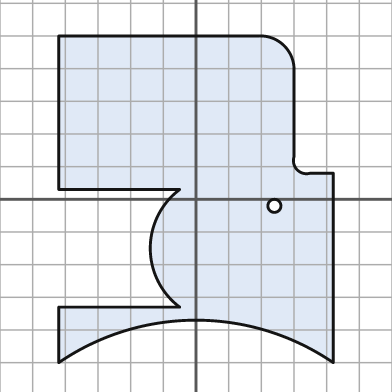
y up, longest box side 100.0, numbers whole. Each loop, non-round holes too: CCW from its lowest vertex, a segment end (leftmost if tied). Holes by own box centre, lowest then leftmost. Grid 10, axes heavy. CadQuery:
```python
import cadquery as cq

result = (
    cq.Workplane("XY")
    .moveTo(-42.0, -50.0)
    .threePointArc((0.0, -37.0), (42.0, -50.0))
    .lineTo(42.0, 8.0)
    .lineTo(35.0, 8.0)
    .threePointArc((31.0, 9.0), (30.0, 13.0))
    .lineTo(30.0, 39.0)
    .threePointArc((27.0, 47.0), (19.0, 50.0))
    .lineTo(-42.0, 50.0)
    .lineTo(-42.0, 3.0)
    .lineTo(-5.0, 3.0)
    .threePointArc((-14.0, -15.0), (-5.0, -33.0))
    .lineTo(-42.0, -33.0)
    .close()
    .moveTo(24.0, -2.0)
    .circle(2.0)
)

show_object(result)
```